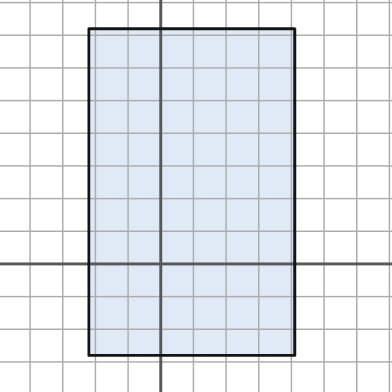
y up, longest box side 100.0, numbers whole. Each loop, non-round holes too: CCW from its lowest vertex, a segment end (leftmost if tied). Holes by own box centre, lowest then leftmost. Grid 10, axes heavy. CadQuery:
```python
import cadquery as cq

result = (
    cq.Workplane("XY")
    .moveTo(-22.0, -28.0)
    .lineTo(41.0, -28.0)
    .lineTo(41.0, 72.0)
    .lineTo(-22.0, 72.0)
    .close()
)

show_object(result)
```